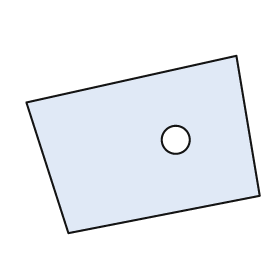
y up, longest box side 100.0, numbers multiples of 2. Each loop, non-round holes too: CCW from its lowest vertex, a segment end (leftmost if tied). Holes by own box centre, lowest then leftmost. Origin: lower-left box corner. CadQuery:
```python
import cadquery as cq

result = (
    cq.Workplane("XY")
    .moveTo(18.0, 0.0)
    .lineTo(100.0, 16.0)
    .lineTo(90.0, 76.0)
    .lineTo(0.0, 56.0)
    .close()
    .moveTo(64.0, 40.0)
    .circle(6.0)
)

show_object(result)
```